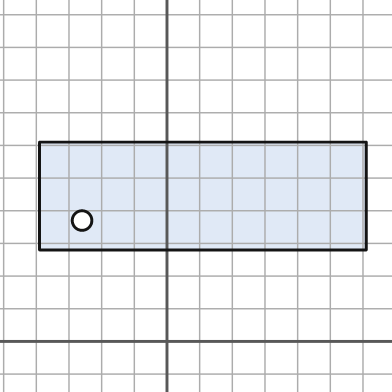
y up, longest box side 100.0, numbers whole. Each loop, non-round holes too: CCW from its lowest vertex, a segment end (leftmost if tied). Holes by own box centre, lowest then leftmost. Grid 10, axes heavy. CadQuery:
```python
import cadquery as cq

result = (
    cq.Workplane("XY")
    .moveTo(-39.0, 28.0)
    .lineTo(61.0, 28.0)
    .lineTo(61.0, 61.0)
    .lineTo(-39.0, 61.0)
    .close()
    .moveTo(-26.0, 37.0)
    .circle(3.0)
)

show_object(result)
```